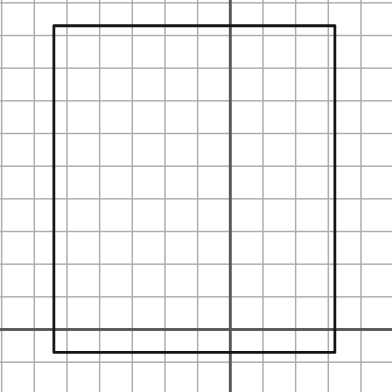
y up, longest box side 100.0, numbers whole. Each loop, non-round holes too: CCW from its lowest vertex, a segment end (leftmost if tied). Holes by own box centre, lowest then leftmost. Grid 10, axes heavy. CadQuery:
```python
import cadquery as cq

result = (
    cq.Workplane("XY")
    .moveTo(-54.0, -7.0)
    .lineTo(32.0, -7.0)
    .lineTo(32.0, 93.0)
    .lineTo(-54.0, 93.0)
    .close()
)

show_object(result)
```